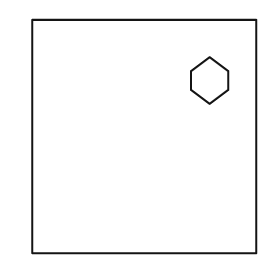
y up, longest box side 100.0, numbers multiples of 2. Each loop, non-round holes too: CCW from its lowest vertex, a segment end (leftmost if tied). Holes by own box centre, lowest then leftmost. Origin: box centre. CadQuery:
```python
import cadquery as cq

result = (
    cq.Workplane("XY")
    .moveTo(-48.0, -50.0)
    .lineTo(48.0, -50.0)
    .lineTo(48.0, 50.0)
    .lineTo(-48.0, 50.0)
    .close()
    .moveTo(28.0, 14.0)
    .lineTo(36.0, 20.0)
    .lineTo(36.0, 28.0)
    .lineTo(28.0, 34.0)
    .lineTo(20.0, 28.0)
    .lineTo(20.0, 20.0)
    .close()
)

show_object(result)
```